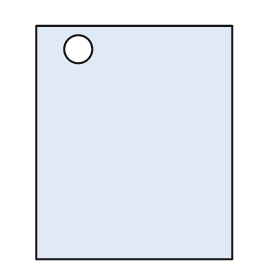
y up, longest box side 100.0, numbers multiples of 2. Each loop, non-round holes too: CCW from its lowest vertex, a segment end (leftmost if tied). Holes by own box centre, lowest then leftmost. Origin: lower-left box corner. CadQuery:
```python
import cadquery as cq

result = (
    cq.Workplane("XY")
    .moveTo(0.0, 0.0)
    .lineTo(84.0, 0.0)
    .lineTo(84.0, 100.0)
    .lineTo(0.0, 100.0)
    .close()
    .moveTo(18.0, 90.0)
    .circle(6.0)
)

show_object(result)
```